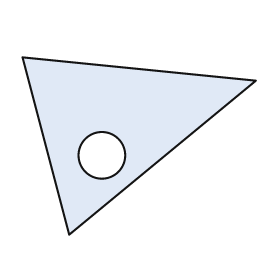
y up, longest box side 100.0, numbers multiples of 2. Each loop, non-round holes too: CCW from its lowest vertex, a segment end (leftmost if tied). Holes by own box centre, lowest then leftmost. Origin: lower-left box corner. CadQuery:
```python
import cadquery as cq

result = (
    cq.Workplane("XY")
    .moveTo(20.0, 0.0)
    .lineTo(100.0, 66.0)
    .lineTo(0.0, 76.0)
    .close()
    .moveTo(34.0, 34.0)
    .circle(10.0)
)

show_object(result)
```